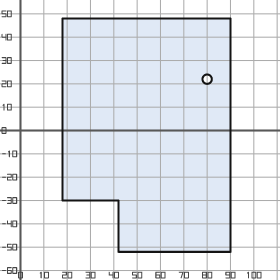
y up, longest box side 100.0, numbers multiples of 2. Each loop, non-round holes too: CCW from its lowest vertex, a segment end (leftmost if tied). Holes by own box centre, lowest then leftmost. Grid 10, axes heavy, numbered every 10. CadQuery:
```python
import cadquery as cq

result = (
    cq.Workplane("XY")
    .moveTo(42.0, -52.0)
    .lineTo(90.0, -52.0)
    .lineTo(90.0, 48.0)
    .lineTo(18.0, 48.0)
    .lineTo(18.0, -30.0)
    .lineTo(42.0, -30.0)
    .close()
    .moveTo(80.0, 22.0)
    .circle(2.0)
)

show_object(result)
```